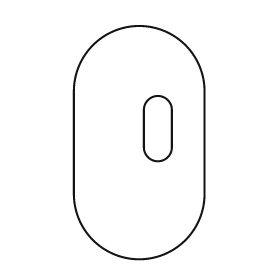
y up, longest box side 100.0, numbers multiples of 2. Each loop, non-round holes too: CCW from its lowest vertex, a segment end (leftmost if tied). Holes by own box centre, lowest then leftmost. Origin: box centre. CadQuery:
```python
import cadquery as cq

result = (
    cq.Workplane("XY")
    .moveTo(-28.0, -22.0)
    .threePointArc((0.0, -50.0), (28.0, -22.0))
    .lineTo(28.0, 22.0)
    .threePointArc((0.0, 50.0), (-28.0, 22.0))
    .close()
    .moveTo(2.0, -2.0)
    .threePointArc((8.0, -8.0), (14.0, -2.0))
    .lineTo(14.0, 14.0)
    .threePointArc((8.0, 20.0), (2.0, 14.0))
    .close()
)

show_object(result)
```